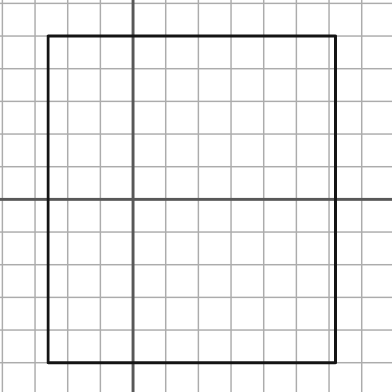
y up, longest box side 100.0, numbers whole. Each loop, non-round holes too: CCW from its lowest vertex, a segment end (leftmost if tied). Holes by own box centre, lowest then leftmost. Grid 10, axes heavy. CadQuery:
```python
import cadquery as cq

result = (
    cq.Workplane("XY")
    .moveTo(-26.0, -50.0)
    .lineTo(62.0, -50.0)
    .lineTo(62.0, 50.0)
    .lineTo(-26.0, 50.0)
    .close()
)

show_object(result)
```